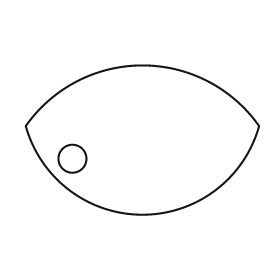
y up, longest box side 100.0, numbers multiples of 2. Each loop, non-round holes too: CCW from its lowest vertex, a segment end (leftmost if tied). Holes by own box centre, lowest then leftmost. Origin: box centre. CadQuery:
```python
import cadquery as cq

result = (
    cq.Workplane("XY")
    .moveTo(-50.0, 6.0)
    .threePointArc((0.0, -32.0), (50.0, 6.0))
    .threePointArc((0.0, 32.0), (-50.0, 6.0))
    .close()
    .moveTo(-30.0, -8.0)
    .circle(6.0)
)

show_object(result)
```